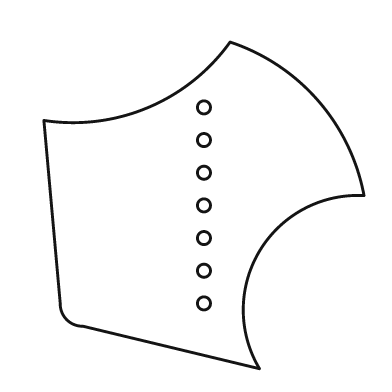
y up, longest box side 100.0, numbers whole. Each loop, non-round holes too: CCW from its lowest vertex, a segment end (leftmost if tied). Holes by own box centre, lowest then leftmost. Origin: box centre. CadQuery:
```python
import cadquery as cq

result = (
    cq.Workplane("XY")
    .moveTo(17.0, -50.0)
    .threePointArc((17.0, -14.0), (49.0, 3.0))
    .threePointArc((35.0, 32.0), (8.0, 50.0))
    .threePointArc((-17.0, 30.0), (-49.0, 26.0))
    .lineTo(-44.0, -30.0)
    .threePointArc((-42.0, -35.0), (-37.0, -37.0))
    .close()
    .moveTo(0.0, -30.0)
    .circle(2.0)
    .moveTo(0.0, -20.0)
    .circle(2.0)
    .moveTo(0.0, -10.0)
    .circle(2.0)
    .moveTo(0.0, 0.0)
    .circle(2.0)
    .moveTo(0.0, 10.0)
    .circle(2.0)
    .moveTo(0.0, 20.0)
    .circle(2.0)
    .moveTo(0.0, 30.0)
    .circle(2.0)
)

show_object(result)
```